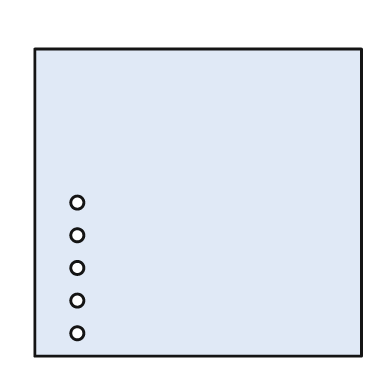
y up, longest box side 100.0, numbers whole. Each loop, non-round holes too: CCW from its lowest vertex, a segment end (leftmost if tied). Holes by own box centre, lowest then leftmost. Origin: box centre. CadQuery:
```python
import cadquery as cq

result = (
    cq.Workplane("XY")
    .moveTo(-50.0, -47.0)
    .lineTo(50.0, -47.0)
    .lineTo(50.0, 47.0)
    .lineTo(-50.0, 47.0)
    .close()
    .moveTo(-37.0, -40.0)
    .circle(2.0)
    .moveTo(-37.0, -30.0)
    .circle(2.0)
    .moveTo(-37.0, -20.0)
    .circle(2.0)
    .moveTo(-37.0, -10.0)
    .circle(2.0)
    .moveTo(-37.0, 0.0)
    .circle(2.0)
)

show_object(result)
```